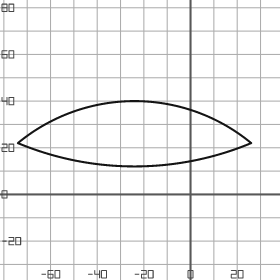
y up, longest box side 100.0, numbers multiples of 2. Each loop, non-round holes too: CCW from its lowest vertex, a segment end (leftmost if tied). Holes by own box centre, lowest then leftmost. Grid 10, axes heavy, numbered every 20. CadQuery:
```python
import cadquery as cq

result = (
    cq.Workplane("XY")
    .moveTo(-74.0, 22.0)
    .threePointArc((-24.0, 12.0), (26.0, 22.0))
    .threePointArc((-24.0, 40.0), (-74.0, 22.0))
    .close()
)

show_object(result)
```